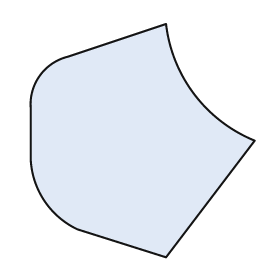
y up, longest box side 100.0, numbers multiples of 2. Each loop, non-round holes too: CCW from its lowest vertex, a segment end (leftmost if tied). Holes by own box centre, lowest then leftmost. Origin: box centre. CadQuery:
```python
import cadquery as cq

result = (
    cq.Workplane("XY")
    .moveTo(10.0, -50.0)
    .lineTo(48.0, 0.0)
    .threePointArc((22.0, 20.0), (10.0, 50.0))
    .lineTo(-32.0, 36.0)
    .threePointArc((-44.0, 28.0), (-48.0, 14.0))
    .lineTo(-48.0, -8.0)
    .threePointArc((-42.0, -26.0), (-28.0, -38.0))
    .close()
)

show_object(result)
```